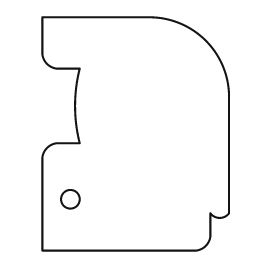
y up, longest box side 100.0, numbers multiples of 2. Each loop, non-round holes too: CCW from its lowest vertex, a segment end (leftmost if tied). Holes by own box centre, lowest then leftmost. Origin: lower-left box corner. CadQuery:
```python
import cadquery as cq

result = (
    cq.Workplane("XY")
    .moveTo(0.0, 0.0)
    .lineTo(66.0, 0.0)
    .threePointArc((70.0, 2.0), (72.0, 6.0))
    .lineTo(72.0, 16.0)
    .threePointArc((76.0, 14.0), (80.0, 16.0))
    .lineTo(80.0, 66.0)
    .threePointArc((70.0, 90.0), (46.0, 100.0))
    .lineTo(0.0, 100.0)
    .lineTo(0.0, 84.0)
    .threePointArc((2.0, 80.0), (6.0, 78.0))
    .lineTo(16.0, 78.0)
    .threePointArc((14.0, 62.0), (16.0, 46.0))
    .lineTo(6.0, 46.0)
    .threePointArc((2.0, 44.0), (0.0, 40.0))
    .close()
    .moveTo(12.0, 22.0)
    .circle(4.0)
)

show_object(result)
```